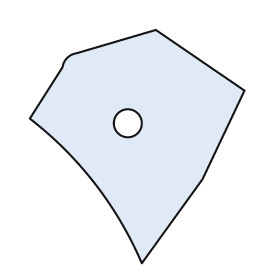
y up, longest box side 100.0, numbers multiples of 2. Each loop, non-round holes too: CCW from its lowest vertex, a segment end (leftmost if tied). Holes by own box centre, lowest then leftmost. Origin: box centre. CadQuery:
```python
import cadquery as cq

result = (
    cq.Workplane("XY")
    .moveTo(2.0, -50.0)
    .lineTo(28.0, -14.0)
    .lineTo(46.0, 24.0)
    .lineTo(8.0, 50.0)
    .lineTo(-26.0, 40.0)
    .threePointArc((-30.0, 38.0), (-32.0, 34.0))
    .lineTo(-46.0, 12.0)
    .threePointArc((-18.0, -16.0), (2.0, -50.0))
    .close()
    .moveTo(-4.0, 10.0)
    .circle(6.0)
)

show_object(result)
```